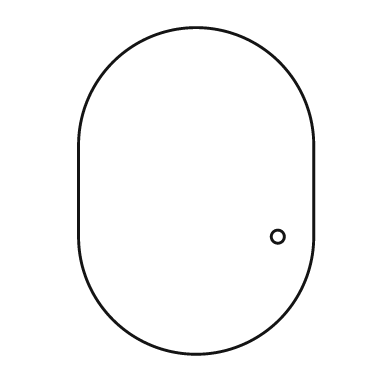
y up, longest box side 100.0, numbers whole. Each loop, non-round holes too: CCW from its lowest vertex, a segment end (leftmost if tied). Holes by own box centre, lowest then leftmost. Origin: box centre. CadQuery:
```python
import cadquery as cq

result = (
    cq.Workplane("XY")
    .moveTo(-36.0, -14.0)
    .threePointArc((0.0, -50.0), (36.0, -14.0))
    .lineTo(36.0, 14.0)
    .threePointArc((0.0, 50.0), (-36.0, 14.0))
    .close()
    .moveTo(25.0, -14.0)
    .circle(2.0)
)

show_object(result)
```